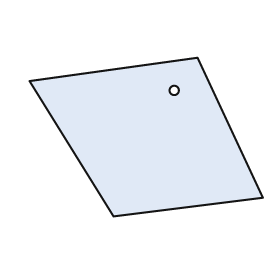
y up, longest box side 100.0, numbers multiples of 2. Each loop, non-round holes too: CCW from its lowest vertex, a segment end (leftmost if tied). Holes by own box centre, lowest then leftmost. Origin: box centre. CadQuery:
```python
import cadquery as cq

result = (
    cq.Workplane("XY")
    .moveTo(-14.0, -34.0)
    .lineTo(50.0, -26.0)
    .lineTo(22.0, 34.0)
    .lineTo(-50.0, 24.0)
    .close()
    .moveTo(12.0, 20.0)
    .circle(2.0)
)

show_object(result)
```